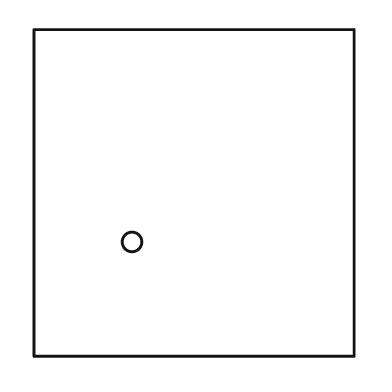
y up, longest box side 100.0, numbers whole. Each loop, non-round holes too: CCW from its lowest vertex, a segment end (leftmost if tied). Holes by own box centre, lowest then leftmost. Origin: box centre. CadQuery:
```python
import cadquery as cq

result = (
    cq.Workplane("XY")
    .moveTo(-49.0, -50.0)
    .lineTo(49.0, -50.0)
    .lineTo(49.0, 50.0)
    .lineTo(-49.0, 50.0)
    .close()
    .moveTo(-19.0, -15.0)
    .circle(3.0)
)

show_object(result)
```